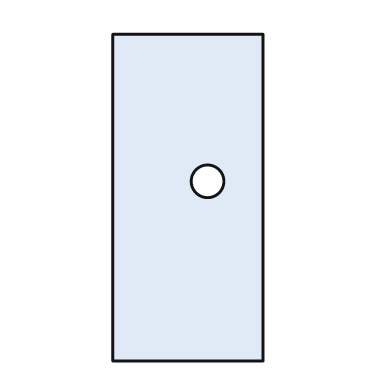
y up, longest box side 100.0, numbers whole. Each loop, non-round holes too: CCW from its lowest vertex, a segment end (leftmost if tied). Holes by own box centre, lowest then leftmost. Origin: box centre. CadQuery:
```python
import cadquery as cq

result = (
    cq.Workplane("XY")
    .moveTo(-23.0, -50.0)
    .lineTo(23.0, -50.0)
    .lineTo(23.0, 50.0)
    .lineTo(-23.0, 50.0)
    .close()
    .moveTo(6.0, 5.0)
    .circle(5.0)
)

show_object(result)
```